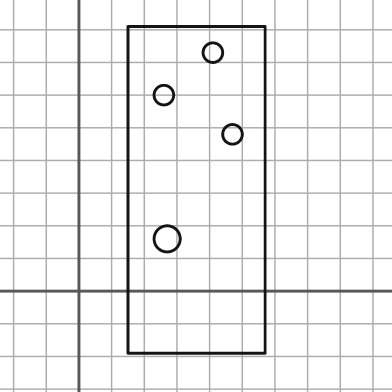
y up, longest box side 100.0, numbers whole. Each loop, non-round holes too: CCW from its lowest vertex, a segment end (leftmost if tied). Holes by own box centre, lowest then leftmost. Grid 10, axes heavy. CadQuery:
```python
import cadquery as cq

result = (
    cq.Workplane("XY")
    .moveTo(15.0, -19.0)
    .lineTo(57.0, -19.0)
    .lineTo(57.0, 81.0)
    .lineTo(15.0, 81.0)
    .close()
    .moveTo(27.0, 16.0)
    .circle(4.0)
    .moveTo(47.0, 48.0)
    .circle(3.0)
    .moveTo(26.0, 60.0)
    .circle(3.0)
    .moveTo(41.0, 73.0)
    .circle(3.0)
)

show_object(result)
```